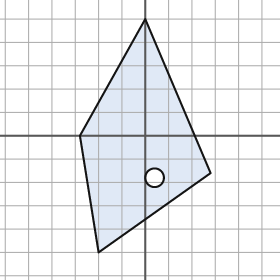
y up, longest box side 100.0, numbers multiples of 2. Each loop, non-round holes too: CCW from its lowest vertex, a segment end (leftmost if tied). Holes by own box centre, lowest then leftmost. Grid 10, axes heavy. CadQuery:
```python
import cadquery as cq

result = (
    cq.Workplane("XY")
    .moveTo(-20.0, -50.0)
    .lineTo(28.0, -16.0)
    .lineTo(0.0, 50.0)
    .lineTo(-28.0, 0.0)
    .close()
    .moveTo(4.0, -18.0)
    .circle(4.0)
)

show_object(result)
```